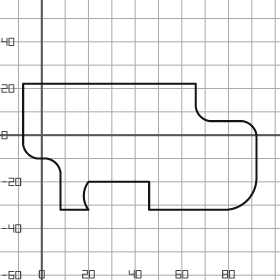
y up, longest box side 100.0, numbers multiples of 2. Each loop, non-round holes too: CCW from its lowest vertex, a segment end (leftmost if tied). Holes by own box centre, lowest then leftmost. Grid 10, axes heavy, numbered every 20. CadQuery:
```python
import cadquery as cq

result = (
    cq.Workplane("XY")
    .moveTo(8.0, -32.0)
    .lineTo(20.0, -32.0)
    .threePointArc((18.0, -26.0), (20.0, -20.0))
    .lineTo(46.0, -20.0)
    .lineTo(46.0, -32.0)
    .lineTo(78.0, -32.0)
    .threePointArc((88.0, -28.0), (92.0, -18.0))
    .lineTo(92.0, 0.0)
    .threePointArc((90.0, 4.0), (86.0, 6.0))
    .lineTo(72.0, 6.0)
    .threePointArc((68.0, 8.0), (66.0, 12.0))
    .lineTo(66.0, 22.0)
    .lineTo(-8.0, 22.0)
    .lineTo(-8.0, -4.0)
    .threePointArc((-6.0, -8.0), (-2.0, -10.0))
    .lineTo(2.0, -10.0)
    .threePointArc((6.0, -12.0), (8.0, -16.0))
    .close()
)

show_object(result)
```